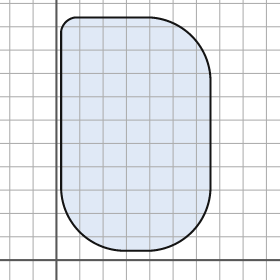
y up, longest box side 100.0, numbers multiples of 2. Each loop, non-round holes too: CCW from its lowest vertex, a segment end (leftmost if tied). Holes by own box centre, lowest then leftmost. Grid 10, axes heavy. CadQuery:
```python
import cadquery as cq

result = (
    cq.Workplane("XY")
    .moveTo(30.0, 4.0)
    .lineTo(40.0, 4.0)
    .threePointArc((58.0, 12.0), (66.0, 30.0))
    .lineTo(66.0, 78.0)
    .threePointArc((58.0, 96.0), (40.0, 104.0))
    .lineTo(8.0, 104.0)
    .threePointArc((4.0, 102.0), (2.0, 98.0))
    .lineTo(2.0, 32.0)
    .threePointArc((10.0, 12.0), (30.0, 4.0))
    .close()
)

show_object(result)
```